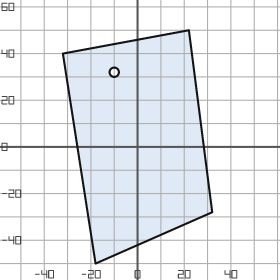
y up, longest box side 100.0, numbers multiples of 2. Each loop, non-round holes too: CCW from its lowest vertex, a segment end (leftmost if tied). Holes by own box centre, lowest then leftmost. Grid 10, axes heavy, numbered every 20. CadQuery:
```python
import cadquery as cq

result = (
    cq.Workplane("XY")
    .moveTo(-18.0, -50.0)
    .lineTo(32.0, -28.0)
    .lineTo(22.0, 50.0)
    .lineTo(-32.0, 40.0)
    .close()
    .moveTo(-10.0, 32.0)
    .circle(2.0)
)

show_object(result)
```